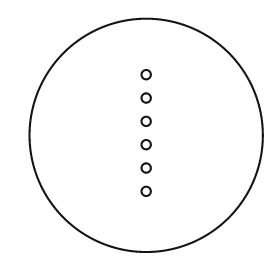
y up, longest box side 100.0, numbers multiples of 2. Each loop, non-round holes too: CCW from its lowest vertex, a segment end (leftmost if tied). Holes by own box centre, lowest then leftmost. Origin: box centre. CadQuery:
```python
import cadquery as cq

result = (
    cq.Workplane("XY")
    .moveTo(0.0, 0.0)
    .circle(50.0)
    .moveTo(0.0, -24.0)
    .circle(2.0)
    .moveTo(0.0, -14.0)
    .circle(2.0)
    .moveTo(0.0, -4.0)
    .circle(2.0)
    .moveTo(0.0, 6.0)
    .circle(2.0)
    .moveTo(0.0, 16.0)
    .circle(2.0)
    .moveTo(0.0, 26.0)
    .circle(2.0)
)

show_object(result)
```